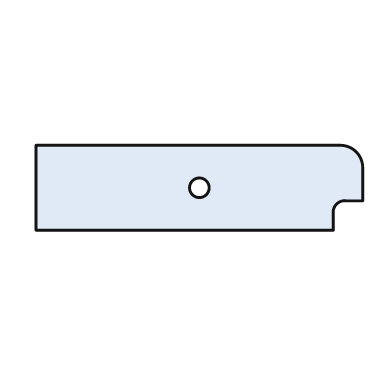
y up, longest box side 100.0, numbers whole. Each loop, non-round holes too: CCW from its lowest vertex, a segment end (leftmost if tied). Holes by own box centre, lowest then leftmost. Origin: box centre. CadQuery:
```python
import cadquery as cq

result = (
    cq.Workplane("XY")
    .moveTo(-50.0, -13.0)
    .lineTo(41.0, -13.0)
    .lineTo(41.0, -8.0)
    .threePointArc((42.0, -5.0), (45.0, -4.0))
    .lineTo(50.0, -4.0)
    .lineTo(50.0, 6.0)
    .threePointArc((48.0, 11.0), (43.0, 13.0))
    .lineTo(-50.0, 13.0)
    .close()
    .moveTo(0.0, 0.0)
    .circle(3.0)
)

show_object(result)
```